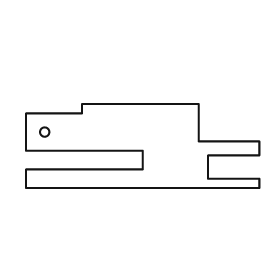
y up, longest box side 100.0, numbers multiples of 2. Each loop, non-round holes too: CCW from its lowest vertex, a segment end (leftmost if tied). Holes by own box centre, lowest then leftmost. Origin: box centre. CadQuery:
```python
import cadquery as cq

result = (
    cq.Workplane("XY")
    .moveTo(-50.0, -18.0)
    .lineTo(50.0, -18.0)
    .lineTo(50.0, -14.0)
    .lineTo(28.0, -14.0)
    .lineTo(28.0, -4.0)
    .lineTo(50.0, -4.0)
    .lineTo(50.0, 2.0)
    .lineTo(24.0, 2.0)
    .lineTo(24.0, 18.0)
    .lineTo(-26.0, 18.0)
    .lineTo(-26.0, 14.0)
    .lineTo(-50.0, 14.0)
    .lineTo(-50.0, -2.0)
    .lineTo(0.0, -2.0)
    .lineTo(0.0, -10.0)
    .lineTo(-50.0, -10.0)
    .close()
    .moveTo(-42.0, 6.0)
    .circle(2.0)
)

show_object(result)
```